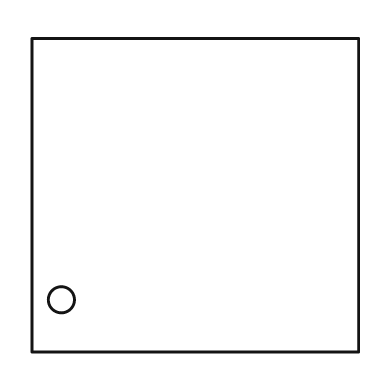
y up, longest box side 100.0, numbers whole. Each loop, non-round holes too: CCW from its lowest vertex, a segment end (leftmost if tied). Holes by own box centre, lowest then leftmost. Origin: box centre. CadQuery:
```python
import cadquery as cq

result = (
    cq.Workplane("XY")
    .moveTo(-50.0, -48.0)
    .lineTo(50.0, -48.0)
    .lineTo(50.0, 48.0)
    .lineTo(-50.0, 48.0)
    .close()
    .moveTo(-41.0, -32.0)
    .circle(4.0)
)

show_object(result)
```